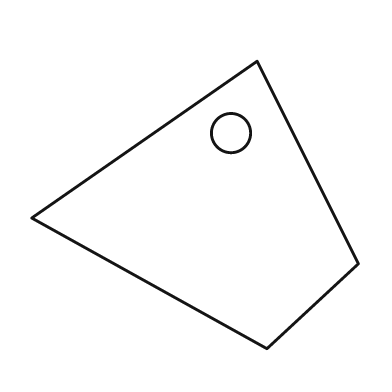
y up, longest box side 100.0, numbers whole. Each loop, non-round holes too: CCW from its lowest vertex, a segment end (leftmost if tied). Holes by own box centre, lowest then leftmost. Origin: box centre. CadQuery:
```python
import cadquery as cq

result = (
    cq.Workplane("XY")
    .moveTo(22.0, -44.0)
    .lineTo(50.0, -18.0)
    .lineTo(19.0, 44.0)
    .lineTo(-50.0, -4.0)
    .close()
    .moveTo(11.0, 22.0)
    .circle(6.0)
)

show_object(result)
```